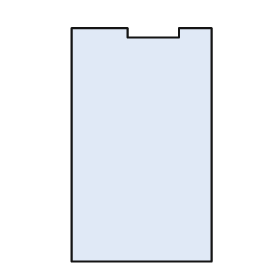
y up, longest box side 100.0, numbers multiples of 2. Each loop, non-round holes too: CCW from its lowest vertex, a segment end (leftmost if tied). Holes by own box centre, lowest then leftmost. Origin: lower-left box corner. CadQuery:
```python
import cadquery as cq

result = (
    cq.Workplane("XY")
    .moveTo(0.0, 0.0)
    .lineTo(60.0, 0.0)
    .lineTo(60.0, 100.0)
    .lineTo(46.0, 100.0)
    .lineTo(46.0, 96.0)
    .lineTo(24.0, 96.0)
    .lineTo(24.0, 100.0)
    .lineTo(0.0, 100.0)
    .close()
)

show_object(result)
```